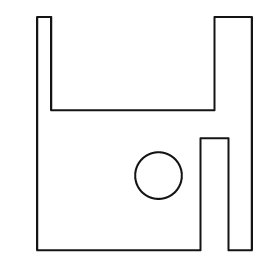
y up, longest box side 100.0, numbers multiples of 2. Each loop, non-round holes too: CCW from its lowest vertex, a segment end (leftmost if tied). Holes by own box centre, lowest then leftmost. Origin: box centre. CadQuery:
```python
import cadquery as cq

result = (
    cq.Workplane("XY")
    .moveTo(-46.0, -50.0)
    .lineTo(24.0, -50.0)
    .lineTo(24.0, -2.0)
    .lineTo(36.0, -2.0)
    .lineTo(36.0, -50.0)
    .lineTo(46.0, -50.0)
    .lineTo(46.0, 50.0)
    .lineTo(30.0, 50.0)
    .lineTo(30.0, 10.0)
    .lineTo(-40.0, 10.0)
    .lineTo(-40.0, 50.0)
    .lineTo(-46.0, 50.0)
    .close()
    .moveTo(6.0, -18.0)
    .circle(10.0)
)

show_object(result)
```